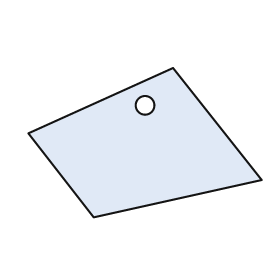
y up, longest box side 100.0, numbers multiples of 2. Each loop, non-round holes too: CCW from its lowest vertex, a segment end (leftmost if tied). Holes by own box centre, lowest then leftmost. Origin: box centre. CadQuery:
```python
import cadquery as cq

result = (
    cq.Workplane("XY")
    .moveTo(-22.0, -32.0)
    .lineTo(50.0, -16.0)
    .lineTo(12.0, 32.0)
    .lineTo(-50.0, 4.0)
    .close()
    .moveTo(0.0, 16.0)
    .circle(4.0)
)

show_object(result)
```